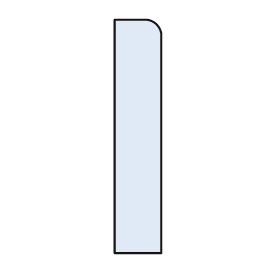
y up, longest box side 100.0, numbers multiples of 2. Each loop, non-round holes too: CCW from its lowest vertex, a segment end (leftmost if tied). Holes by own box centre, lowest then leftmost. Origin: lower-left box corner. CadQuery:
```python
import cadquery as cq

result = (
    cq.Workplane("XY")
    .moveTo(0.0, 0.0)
    .lineTo(20.0, 0.0)
    .lineTo(20.0, 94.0)
    .threePointArc((18.0, 98.0), (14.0, 100.0))
    .lineTo(0.0, 100.0)
    .close()
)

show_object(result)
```